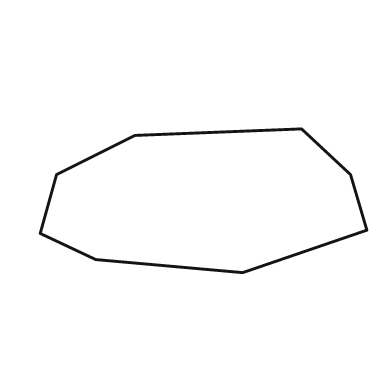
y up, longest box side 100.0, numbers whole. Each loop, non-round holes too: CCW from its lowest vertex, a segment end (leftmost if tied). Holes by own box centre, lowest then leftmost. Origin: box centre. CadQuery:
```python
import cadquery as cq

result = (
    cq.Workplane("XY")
    .moveTo(12.0, -22.0)
    .lineTo(50.0, -9.0)
    .lineTo(45.0, 8.0)
    .lineTo(30.0, 22.0)
    .lineTo(-21.0, 20.0)
    .lineTo(-45.0, 8.0)
    .lineTo(-50.0, -10.0)
    .lineTo(-33.0, -18.0)
    .close()
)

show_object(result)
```